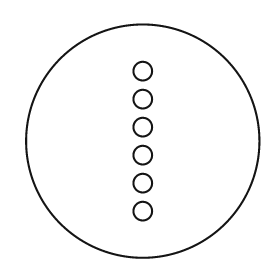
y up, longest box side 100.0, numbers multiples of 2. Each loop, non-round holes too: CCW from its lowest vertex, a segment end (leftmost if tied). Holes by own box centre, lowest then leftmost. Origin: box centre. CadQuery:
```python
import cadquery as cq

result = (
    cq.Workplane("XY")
    .moveTo(0.0, 0.0)
    .circle(50.0)
    .moveTo(0.0, -30.0)
    .circle(4.0)
    .moveTo(0.0, -18.0)
    .circle(4.0)
    .moveTo(0.0, -6.0)
    .circle(4.0)
    .moveTo(0.0, 6.0)
    .circle(4.0)
    .moveTo(0.0, 18.0)
    .circle(4.0)
    .moveTo(0.0, 30.0)
    .circle(4.0)
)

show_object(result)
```